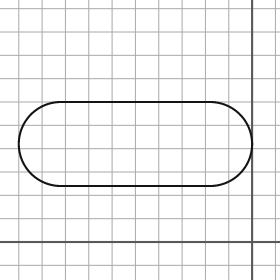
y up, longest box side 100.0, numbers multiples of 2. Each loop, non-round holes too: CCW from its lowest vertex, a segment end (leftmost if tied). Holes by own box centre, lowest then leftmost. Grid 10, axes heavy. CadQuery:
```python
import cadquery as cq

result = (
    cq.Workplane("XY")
    .moveTo(-82.0, 24.0)
    .lineTo(-18.0, 24.0)
    .threePointArc((0.0, 42.0), (-18.0, 60.0))
    .lineTo(-82.0, 60.0)
    .threePointArc((-100.0, 42.0), (-82.0, 24.0))
    .close()
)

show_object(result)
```